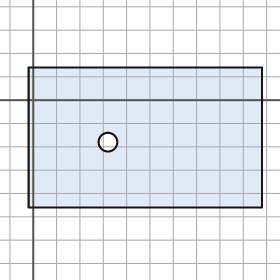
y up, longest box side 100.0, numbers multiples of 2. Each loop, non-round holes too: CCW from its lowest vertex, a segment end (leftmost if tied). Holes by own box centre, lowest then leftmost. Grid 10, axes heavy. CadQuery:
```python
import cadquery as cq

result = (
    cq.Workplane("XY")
    .moveTo(-2.0, -46.0)
    .lineTo(98.0, -46.0)
    .lineTo(98.0, 14.0)
    .lineTo(-2.0, 14.0)
    .close()
    .moveTo(32.0, -18.0)
    .circle(4.0)
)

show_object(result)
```